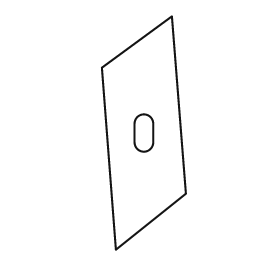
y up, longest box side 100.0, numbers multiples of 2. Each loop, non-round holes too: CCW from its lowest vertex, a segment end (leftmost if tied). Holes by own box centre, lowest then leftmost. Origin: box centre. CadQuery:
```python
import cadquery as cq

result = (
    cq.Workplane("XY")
    .moveTo(-12.0, -50.0)
    .lineTo(18.0, -26.0)
    .lineTo(12.0, 50.0)
    .lineTo(-18.0, 28.0)
    .close()
    .moveTo(-4.0, -4.0)
    .threePointArc((0.0, -8.0), (4.0, -4.0))
    .lineTo(4.0, 4.0)
    .threePointArc((0.0, 8.0), (-4.0, 4.0))
    .close()
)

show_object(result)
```